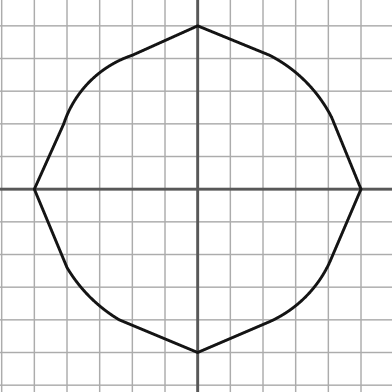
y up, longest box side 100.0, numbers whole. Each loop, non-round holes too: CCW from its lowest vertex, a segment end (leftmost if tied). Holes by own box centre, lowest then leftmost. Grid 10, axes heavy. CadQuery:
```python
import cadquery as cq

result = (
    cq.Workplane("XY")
    .moveTo(0.0, -50.0)
    .lineTo(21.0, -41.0)
    .threePointArc((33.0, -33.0), (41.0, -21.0))
    .lineTo(50.0, 0.0)
    .lineTo(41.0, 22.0)
    .threePointArc((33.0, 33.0), (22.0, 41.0))
    .lineTo(0.0, 50.0)
    .lineTo(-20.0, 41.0)
    .threePointArc((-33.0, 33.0), (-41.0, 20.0))
    .lineTo(-50.0, 0.0)
    .lineTo(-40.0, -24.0)
    .threePointArc((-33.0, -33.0), (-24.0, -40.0))
    .close()
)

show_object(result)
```